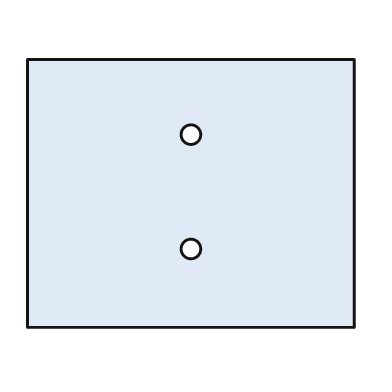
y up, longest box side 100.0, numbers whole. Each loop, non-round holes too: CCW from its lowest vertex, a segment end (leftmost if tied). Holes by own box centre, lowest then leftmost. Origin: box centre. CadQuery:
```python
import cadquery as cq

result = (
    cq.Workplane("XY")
    .moveTo(-50.0, -41.0)
    .lineTo(50.0, -41.0)
    .lineTo(50.0, 41.0)
    .lineTo(-50.0, 41.0)
    .close()
    .moveTo(0.0, -17.0)
    .circle(3.0)
    .moveTo(0.0, 18.0)
    .circle(3.0)
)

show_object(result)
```